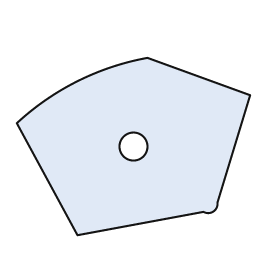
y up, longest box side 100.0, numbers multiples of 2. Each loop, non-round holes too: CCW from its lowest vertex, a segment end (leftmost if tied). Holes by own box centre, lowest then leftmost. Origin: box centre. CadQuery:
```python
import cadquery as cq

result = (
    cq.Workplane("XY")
    .moveTo(-24.0, -38.0)
    .lineTo(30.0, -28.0)
    .threePointArc((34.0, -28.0), (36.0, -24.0))
    .lineTo(50.0, 22.0)
    .lineTo(6.0, 38.0)
    .threePointArc((-24.0, 28.0), (-50.0, 10.0))
    .close()
    .moveTo(0.0, 0.0)
    .circle(6.0)
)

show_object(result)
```